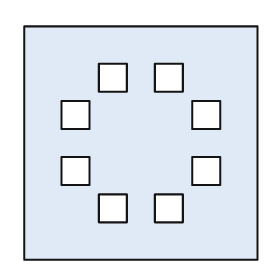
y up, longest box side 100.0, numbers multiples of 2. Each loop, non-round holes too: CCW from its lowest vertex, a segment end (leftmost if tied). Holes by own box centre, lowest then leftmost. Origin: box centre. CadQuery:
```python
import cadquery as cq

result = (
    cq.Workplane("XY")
    .moveTo(-50.0, -50.0)
    .lineTo(50.0, -50.0)
    .lineTo(50.0, 50.0)
    .lineTo(-50.0, 50.0)
    .close()
    .moveTo(-18.0, -34.0)
    .lineTo(-6.0, -34.0)
    .lineTo(-6.0, -22.0)
    .lineTo(-18.0, -22.0)
    .close()
    .moveTo(6.0, -34.0)
    .lineTo(18.0, -34.0)
    .lineTo(18.0, -22.0)
    .lineTo(6.0, -22.0)
    .close()
    .moveTo(-34.0, -18.0)
    .lineTo(-22.0, -18.0)
    .lineTo(-22.0, -6.0)
    .lineTo(-34.0, -6.0)
    .close()
    .moveTo(22.0, -18.0)
    .lineTo(34.0, -18.0)
    .lineTo(34.0, -6.0)
    .lineTo(22.0, -6.0)
    .close()
    .moveTo(-34.0, 6.0)
    .lineTo(-22.0, 6.0)
    .lineTo(-22.0, 18.0)
    .lineTo(-34.0, 18.0)
    .close()
    .moveTo(22.0, 6.0)
    .lineTo(34.0, 6.0)
    .lineTo(34.0, 18.0)
    .lineTo(22.0, 18.0)
    .close()
    .moveTo(-18.0, 22.0)
    .lineTo(-6.0, 22.0)
    .lineTo(-6.0, 34.0)
    .lineTo(-18.0, 34.0)
    .close()
    .moveTo(6.0, 22.0)
    .lineTo(18.0, 22.0)
    .lineTo(18.0, 34.0)
    .lineTo(6.0, 34.0)
    .close()
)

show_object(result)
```